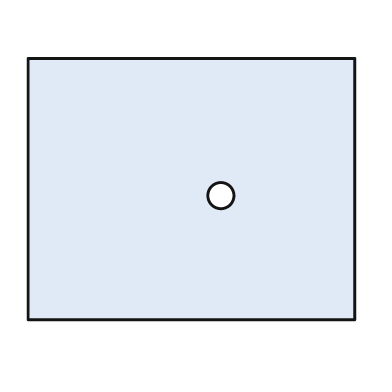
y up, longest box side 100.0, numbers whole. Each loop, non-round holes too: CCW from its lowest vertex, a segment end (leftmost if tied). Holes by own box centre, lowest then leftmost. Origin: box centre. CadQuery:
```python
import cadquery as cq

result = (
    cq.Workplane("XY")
    .moveTo(-50.0, -40.0)
    .lineTo(50.0, -40.0)
    .lineTo(50.0, 40.0)
    .lineTo(-50.0, 40.0)
    .close()
    .moveTo(9.0, -2.0)
    .circle(4.0)
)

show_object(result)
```